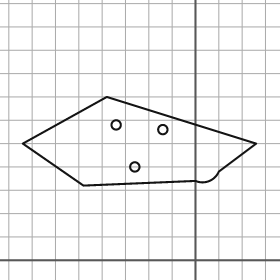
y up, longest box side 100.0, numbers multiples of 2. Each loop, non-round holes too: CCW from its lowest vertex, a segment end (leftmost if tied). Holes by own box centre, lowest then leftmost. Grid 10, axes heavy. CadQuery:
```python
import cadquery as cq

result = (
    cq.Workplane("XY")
    .moveTo(-48.0, 32.0)
    .lineTo(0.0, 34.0)
    .threePointArc((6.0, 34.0), (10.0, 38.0))
    .lineTo(26.0, 50.0)
    .lineTo(-38.0, 70.0)
    .lineTo(-74.0, 50.0)
    .close()
    .moveTo(-26.0, 40.0)
    .circle(2.0)
    .moveTo(-14.0, 56.0)
    .circle(2.0)
    .moveTo(-34.0, 58.0)
    .circle(2.0)
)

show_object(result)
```